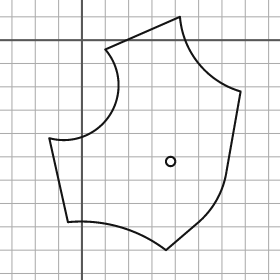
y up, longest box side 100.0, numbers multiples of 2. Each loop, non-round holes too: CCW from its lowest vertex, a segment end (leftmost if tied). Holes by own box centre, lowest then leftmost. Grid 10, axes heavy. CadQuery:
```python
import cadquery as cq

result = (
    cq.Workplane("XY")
    .moveTo(36.0, -90.0)
    .lineTo(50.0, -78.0)
    .threePointArc((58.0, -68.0), (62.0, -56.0))
    .lineTo(68.0, -22.0)
    .threePointArc((50.0, -10.0), (42.0, 10.0))
    .lineTo(10.0, -4.0)
    .threePointArc((12.0, -32.0), (-14.0, -42.0))
    .lineTo(-6.0, -78.0)
    .threePointArc((16.0, -80.0), (36.0, -90.0))
    .close()
    .moveTo(38.0, -52.0)
    .circle(2.0)
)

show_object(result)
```